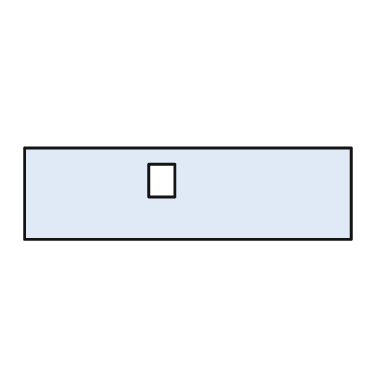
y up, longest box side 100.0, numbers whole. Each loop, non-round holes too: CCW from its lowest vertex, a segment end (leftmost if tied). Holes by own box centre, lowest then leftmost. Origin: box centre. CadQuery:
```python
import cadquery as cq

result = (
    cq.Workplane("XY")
    .moveTo(-50.0, -14.0)
    .lineTo(50.0, -14.0)
    .lineTo(50.0, 14.0)
    .lineTo(-50.0, 14.0)
    .close()
    .moveTo(-12.0, -1.0)
    .lineTo(-4.0, -1.0)
    .lineTo(-4.0, 9.0)
    .lineTo(-12.0, 9.0)
    .close()
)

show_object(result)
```